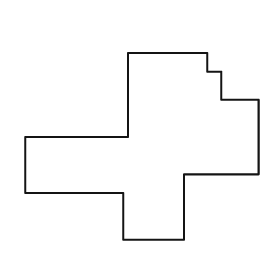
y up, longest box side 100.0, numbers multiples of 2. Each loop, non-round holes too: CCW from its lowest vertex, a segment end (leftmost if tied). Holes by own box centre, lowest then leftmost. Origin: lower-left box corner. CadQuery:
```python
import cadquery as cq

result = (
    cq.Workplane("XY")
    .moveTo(42.0, 0.0)
    .lineTo(68.0, 0.0)
    .lineTo(68.0, 28.0)
    .lineTo(100.0, 28.0)
    .lineTo(100.0, 60.0)
    .lineTo(84.0, 60.0)
    .lineTo(84.0, 72.0)
    .lineTo(78.0, 72.0)
    .lineTo(78.0, 80.0)
    .lineTo(44.0, 80.0)
    .lineTo(44.0, 44.0)
    .lineTo(0.0, 44.0)
    .lineTo(0.0, 20.0)
    .lineTo(42.0, 20.0)
    .close()
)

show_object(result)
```